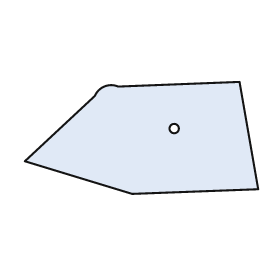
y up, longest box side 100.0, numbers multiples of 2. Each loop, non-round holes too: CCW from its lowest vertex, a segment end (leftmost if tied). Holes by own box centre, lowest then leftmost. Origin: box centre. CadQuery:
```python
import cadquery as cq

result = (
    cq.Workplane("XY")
    .moveTo(-4.0, -24.0)
    .lineTo(50.0, -22.0)
    .lineTo(42.0, 24.0)
    .lineTo(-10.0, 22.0)
    .threePointArc((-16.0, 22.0), (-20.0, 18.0))
    .lineTo(-50.0, -10.0)
    .close()
    .moveTo(14.0, 4.0)
    .circle(2.0)
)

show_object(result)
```